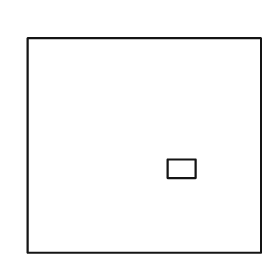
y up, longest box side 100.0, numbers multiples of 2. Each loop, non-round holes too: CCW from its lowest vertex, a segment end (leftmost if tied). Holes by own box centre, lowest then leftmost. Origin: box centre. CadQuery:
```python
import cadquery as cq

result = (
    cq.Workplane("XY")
    .moveTo(-50.0, -46.0)
    .lineTo(50.0, -46.0)
    .lineTo(50.0, 46.0)
    .lineTo(-50.0, 46.0)
    .close()
    .moveTo(10.0, -14.0)
    .lineTo(22.0, -14.0)
    .lineTo(22.0, -6.0)
    .lineTo(10.0, -6.0)
    .close()
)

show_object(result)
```